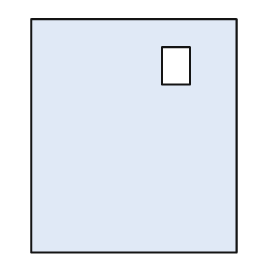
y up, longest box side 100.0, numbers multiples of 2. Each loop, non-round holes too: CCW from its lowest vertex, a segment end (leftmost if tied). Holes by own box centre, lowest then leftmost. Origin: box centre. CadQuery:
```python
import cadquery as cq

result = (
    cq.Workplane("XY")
    .moveTo(-44.0, -50.0)
    .lineTo(44.0, -50.0)
    .lineTo(44.0, 50.0)
    .lineTo(-44.0, 50.0)
    .close()
    .moveTo(12.0, 22.0)
    .lineTo(24.0, 22.0)
    .lineTo(24.0, 38.0)
    .lineTo(12.0, 38.0)
    .close()
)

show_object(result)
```